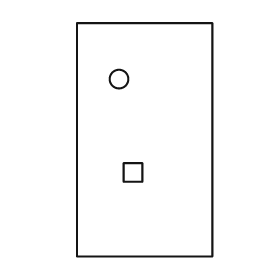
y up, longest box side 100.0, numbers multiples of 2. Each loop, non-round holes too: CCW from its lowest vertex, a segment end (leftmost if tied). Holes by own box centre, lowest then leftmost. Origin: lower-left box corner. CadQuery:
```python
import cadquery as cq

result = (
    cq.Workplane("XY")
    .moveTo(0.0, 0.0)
    .lineTo(58.0, 0.0)
    .lineTo(58.0, 100.0)
    .lineTo(0.0, 100.0)
    .close()
    .moveTo(20.0, 32.0)
    .lineTo(28.0, 32.0)
    .lineTo(28.0, 40.0)
    .lineTo(20.0, 40.0)
    .close()
    .moveTo(18.0, 76.0)
    .circle(4.0)
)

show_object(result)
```